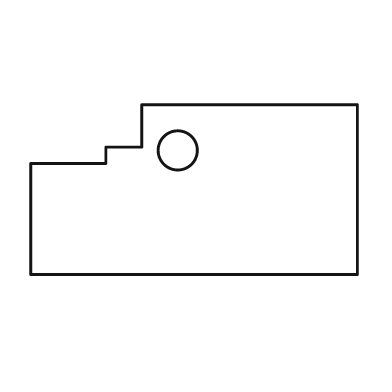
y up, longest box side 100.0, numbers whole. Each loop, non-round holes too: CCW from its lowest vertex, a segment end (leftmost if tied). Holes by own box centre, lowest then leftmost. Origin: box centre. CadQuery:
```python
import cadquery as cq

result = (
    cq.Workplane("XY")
    .moveTo(-50.0, -26.0)
    .lineTo(50.0, -26.0)
    .lineTo(50.0, 26.0)
    .lineTo(-16.0, 26.0)
    .lineTo(-16.0, 13.0)
    .lineTo(-27.0, 13.0)
    .lineTo(-27.0, 8.0)
    .lineTo(-50.0, 8.0)
    .close()
    .moveTo(-5.0, 12.0)
    .circle(6.0)
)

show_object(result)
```